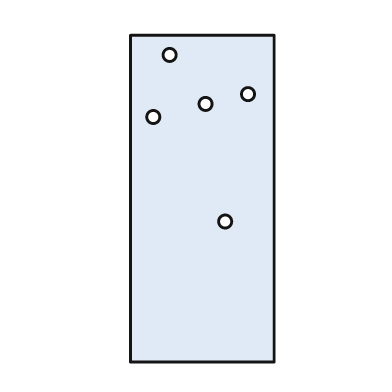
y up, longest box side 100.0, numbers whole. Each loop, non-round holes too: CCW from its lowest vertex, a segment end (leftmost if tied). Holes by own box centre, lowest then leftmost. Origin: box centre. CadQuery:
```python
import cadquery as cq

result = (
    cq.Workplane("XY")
    .moveTo(-22.0, -50.0)
    .lineTo(22.0, -50.0)
    .lineTo(22.0, 50.0)
    .lineTo(-22.0, 50.0)
    .close()
    .moveTo(7.0, -7.0)
    .circle(2.0)
    .moveTo(-15.0, 25.0)
    .circle(2.0)
    .moveTo(1.0, 29.0)
    .circle(2.0)
    .moveTo(14.0, 32.0)
    .circle(2.0)
    .moveTo(-10.0, 44.0)
    .circle(2.0)
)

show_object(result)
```